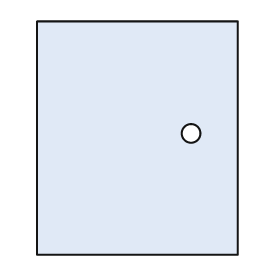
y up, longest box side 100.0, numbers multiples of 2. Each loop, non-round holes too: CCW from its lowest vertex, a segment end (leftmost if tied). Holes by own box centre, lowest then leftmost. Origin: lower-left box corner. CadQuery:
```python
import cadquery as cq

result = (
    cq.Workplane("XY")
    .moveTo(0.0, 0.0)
    .lineTo(86.0, 0.0)
    .lineTo(86.0, 100.0)
    .lineTo(0.0, 100.0)
    .close()
    .moveTo(66.0, 52.0)
    .circle(4.0)
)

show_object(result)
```